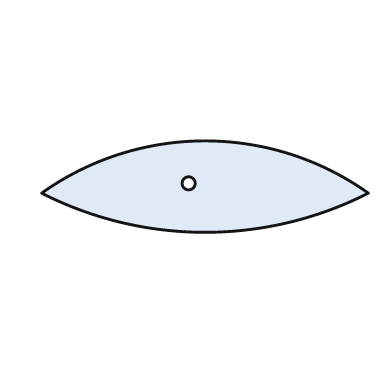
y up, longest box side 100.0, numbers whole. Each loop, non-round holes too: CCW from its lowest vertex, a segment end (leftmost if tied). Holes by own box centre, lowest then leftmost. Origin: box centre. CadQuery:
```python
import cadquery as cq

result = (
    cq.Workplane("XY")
    .moveTo(-50.0, -2.0)
    .threePointArc((0.0, -14.0), (50.0, -2.0))
    .threePointArc((0.0, 14.0), (-50.0, -2.0))
    .close()
    .moveTo(-5.0, 1.0)
    .circle(2.0)
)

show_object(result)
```